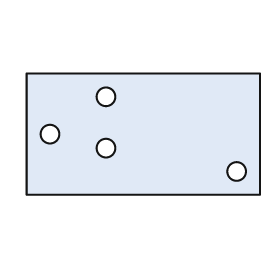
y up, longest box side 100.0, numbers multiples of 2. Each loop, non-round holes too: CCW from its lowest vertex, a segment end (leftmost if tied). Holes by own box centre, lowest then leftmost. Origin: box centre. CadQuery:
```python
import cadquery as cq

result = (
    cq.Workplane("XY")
    .moveTo(-50.0, -26.0)
    .lineTo(50.0, -26.0)
    .lineTo(50.0, 26.0)
    .lineTo(-50.0, 26.0)
    .close()
    .moveTo(40.0, -16.0)
    .circle(4.0)
    .moveTo(-16.0, -6.0)
    .circle(4.0)
    .moveTo(-40.0, 0.0)
    .circle(4.0)
    .moveTo(-16.0, 16.0)
    .circle(4.0)
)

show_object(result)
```